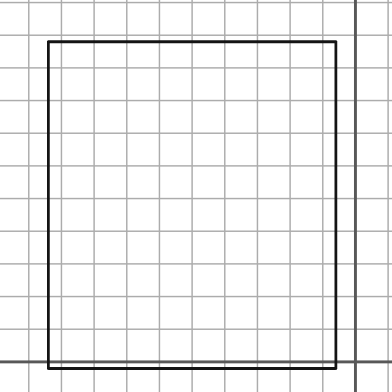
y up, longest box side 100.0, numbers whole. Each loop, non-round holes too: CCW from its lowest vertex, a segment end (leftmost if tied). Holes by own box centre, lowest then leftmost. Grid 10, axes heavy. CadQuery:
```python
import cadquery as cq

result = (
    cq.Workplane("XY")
    .moveTo(-94.0, -2.0)
    .lineTo(-6.0, -2.0)
    .lineTo(-6.0, 98.0)
    .lineTo(-94.0, 98.0)
    .close()
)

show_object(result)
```